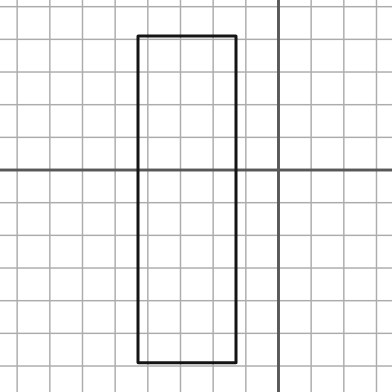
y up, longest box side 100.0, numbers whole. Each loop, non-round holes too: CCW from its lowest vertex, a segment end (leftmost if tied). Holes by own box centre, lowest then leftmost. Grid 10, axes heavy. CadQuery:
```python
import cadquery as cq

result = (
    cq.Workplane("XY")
    .moveTo(-43.0, -59.0)
    .lineTo(-13.0, -59.0)
    .lineTo(-13.0, 41.0)
    .lineTo(-43.0, 41.0)
    .close()
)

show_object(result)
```